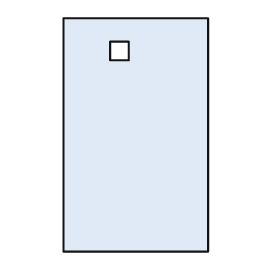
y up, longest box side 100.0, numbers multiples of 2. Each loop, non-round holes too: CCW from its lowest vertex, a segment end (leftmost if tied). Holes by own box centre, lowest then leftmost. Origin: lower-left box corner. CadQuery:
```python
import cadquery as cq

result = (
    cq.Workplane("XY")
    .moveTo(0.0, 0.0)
    .lineTo(62.0, 0.0)
    .lineTo(62.0, 100.0)
    .lineTo(0.0, 100.0)
    .close()
    .moveTo(20.0, 82.0)
    .lineTo(28.0, 82.0)
    .lineTo(28.0, 90.0)
    .lineTo(20.0, 90.0)
    .close()
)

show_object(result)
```